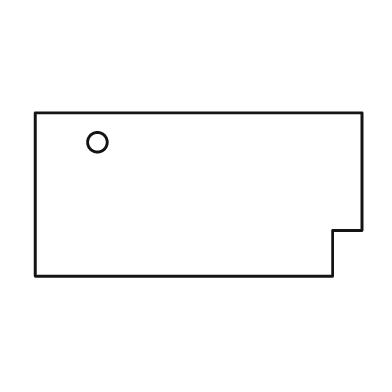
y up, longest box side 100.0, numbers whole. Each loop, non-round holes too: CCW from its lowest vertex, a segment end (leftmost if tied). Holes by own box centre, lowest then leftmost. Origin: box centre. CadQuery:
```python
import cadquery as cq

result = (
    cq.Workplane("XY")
    .moveTo(-50.0, -25.0)
    .lineTo(41.0, -25.0)
    .lineTo(41.0, -11.0)
    .lineTo(50.0, -11.0)
    .lineTo(50.0, 25.0)
    .lineTo(-50.0, 25.0)
    .close()
    .moveTo(-31.0, 16.0)
    .circle(3.0)
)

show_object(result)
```